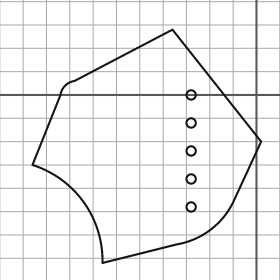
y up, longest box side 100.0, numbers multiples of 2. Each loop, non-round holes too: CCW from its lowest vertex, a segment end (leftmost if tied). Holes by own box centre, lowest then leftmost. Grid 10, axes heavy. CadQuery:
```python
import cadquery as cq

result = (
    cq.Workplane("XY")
    .moveTo(-66.0, -72.0)
    .lineTo(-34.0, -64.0)
    .threePointArc((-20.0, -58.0), (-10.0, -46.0))
    .lineTo(2.0, -20.0)
    .lineTo(-36.0, 28.0)
    .lineTo(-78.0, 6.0)
    .threePointArc((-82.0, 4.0), (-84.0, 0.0))
    .lineTo(-96.0, -30.0)
    .threePointArc((-74.0, -46.0), (-66.0, -72.0))
    .close()
    .moveTo(-28.0, -48.0)
    .circle(2.0)
    .moveTo(-28.0, -36.0)
    .circle(2.0)
    .moveTo(-28.0, -24.0)
    .circle(2.0)
    .moveTo(-28.0, -12.0)
    .circle(2.0)
    .moveTo(-28.0, 0.0)
    .circle(2.0)
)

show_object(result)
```